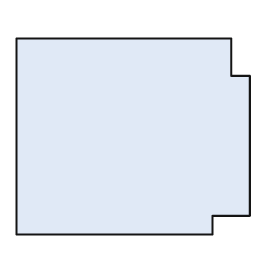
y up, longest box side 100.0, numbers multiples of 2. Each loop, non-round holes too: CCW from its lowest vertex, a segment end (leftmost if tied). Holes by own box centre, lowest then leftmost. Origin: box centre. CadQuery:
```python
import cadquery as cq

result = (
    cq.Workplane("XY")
    .moveTo(-50.0, -42.0)
    .lineTo(34.0, -42.0)
    .lineTo(34.0, -34.0)
    .lineTo(50.0, -34.0)
    .lineTo(50.0, 26.0)
    .lineTo(42.0, 26.0)
    .lineTo(42.0, 42.0)
    .lineTo(-50.0, 42.0)
    .close()
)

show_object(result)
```